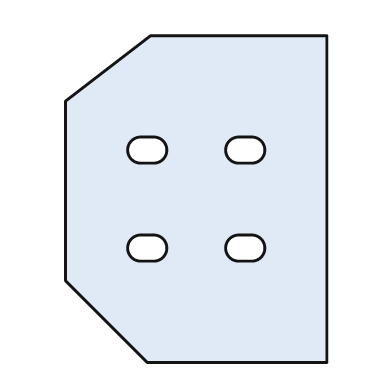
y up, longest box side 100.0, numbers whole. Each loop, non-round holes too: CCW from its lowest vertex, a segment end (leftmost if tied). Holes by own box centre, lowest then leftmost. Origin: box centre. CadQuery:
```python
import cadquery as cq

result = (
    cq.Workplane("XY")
    .moveTo(-15.0, -50.0)
    .lineTo(40.0, -50.0)
    .lineTo(40.0, 50.0)
    .lineTo(-14.0, 50.0)
    .lineTo(-40.0, 30.0)
    .lineTo(-40.0, -25.0)
    .close()
    .moveTo(-17.0, -19.0)
    .lineTo(-13.0, -19.0)
    .threePointArc((-9.0, -15.0), (-13.0, -11.0))
    .lineTo(-17.0, -11.0)
    .threePointArc((-21.0, -15.0), (-17.0, -19.0))
    .close()
    .moveTo(13.0, -19.0)
    .lineTo(17.0, -19.0)
    .threePointArc((21.0, -15.0), (17.0, -11.0))
    .lineTo(13.0, -11.0)
    .threePointArc((9.0, -15.0), (13.0, -19.0))
    .close()
    .moveTo(-17.0, 11.0)
    .lineTo(-13.0, 11.0)
    .threePointArc((-9.0, 15.0), (-13.0, 19.0))
    .lineTo(-17.0, 19.0)
    .threePointArc((-21.0, 15.0), (-17.0, 11.0))
    .close()
    .moveTo(13.0, 11.0)
    .lineTo(17.0, 11.0)
    .threePointArc((21.0, 15.0), (17.0, 19.0))
    .lineTo(13.0, 19.0)
    .threePointArc((9.0, 15.0), (13.0, 11.0))
    .close()
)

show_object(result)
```